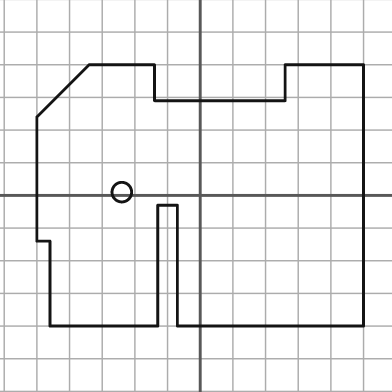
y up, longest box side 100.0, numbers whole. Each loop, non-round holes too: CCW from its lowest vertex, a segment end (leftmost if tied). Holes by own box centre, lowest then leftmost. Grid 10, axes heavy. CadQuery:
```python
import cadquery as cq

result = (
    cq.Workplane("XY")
    .moveTo(-46.0, -40.0)
    .lineTo(-13.0, -40.0)
    .lineTo(-13.0, -3.0)
    .lineTo(-7.0, -3.0)
    .lineTo(-7.0, -40.0)
    .lineTo(50.0, -40.0)
    .lineTo(50.0, 40.0)
    .lineTo(26.0, 40.0)
    .lineTo(26.0, 29.0)
    .lineTo(-14.0, 29.0)
    .lineTo(-14.0, 40.0)
    .lineTo(-34.0, 40.0)
    .lineTo(-50.0, 24.0)
    .lineTo(-50.0, -14.0)
    .lineTo(-46.0, -14.0)
    .close()
    .moveTo(-24.0, 1.0)
    .circle(3.0)
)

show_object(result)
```